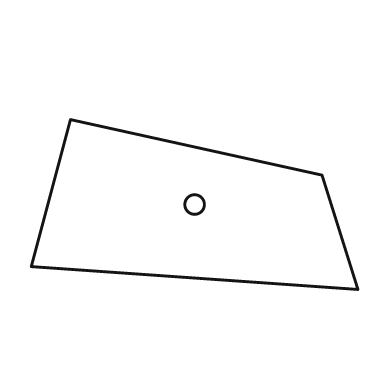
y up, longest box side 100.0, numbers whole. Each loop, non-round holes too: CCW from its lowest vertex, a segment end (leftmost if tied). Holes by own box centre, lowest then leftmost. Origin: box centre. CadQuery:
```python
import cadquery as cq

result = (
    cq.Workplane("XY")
    .moveTo(50.0, -26.0)
    .lineTo(39.0, 9.0)
    .lineTo(-38.0, 26.0)
    .lineTo(-50.0, -19.0)
    .close()
    .moveTo(0.0, 0.0)
    .circle(3.0)
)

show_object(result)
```